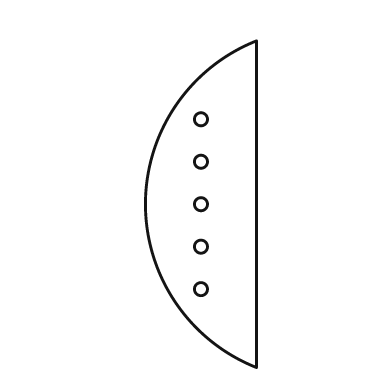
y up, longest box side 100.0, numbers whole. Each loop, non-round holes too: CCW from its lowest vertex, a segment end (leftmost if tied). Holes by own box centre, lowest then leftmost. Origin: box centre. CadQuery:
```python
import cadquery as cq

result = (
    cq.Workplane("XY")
    .moveTo(17.0, -50.0)
    .lineTo(17.0, 50.0)
    .threePointArc((-17.0, 0.0), (17.0, -50.0))
    .close()
    .moveTo(0.0, -26.0)
    .circle(2.0)
    .moveTo(0.0, -13.0)
    .circle(2.0)
    .moveTo(0.0, 0.0)
    .circle(2.0)
    .moveTo(0.0, 13.0)
    .circle(2.0)
    .moveTo(0.0, 26.0)
    .circle(2.0)
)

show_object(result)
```